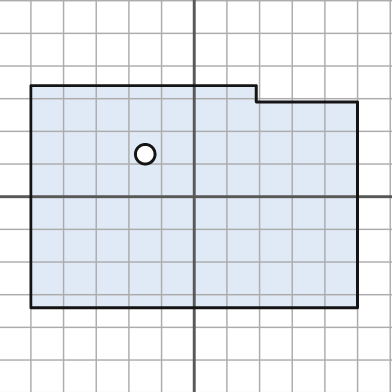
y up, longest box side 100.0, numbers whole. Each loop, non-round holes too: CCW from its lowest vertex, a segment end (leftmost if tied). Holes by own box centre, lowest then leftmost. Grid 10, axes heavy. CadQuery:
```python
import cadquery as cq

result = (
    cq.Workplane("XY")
    .moveTo(-50.0, -34.0)
    .lineTo(50.0, -34.0)
    .lineTo(50.0, 29.0)
    .lineTo(19.0, 29.0)
    .lineTo(19.0, 34.0)
    .lineTo(-50.0, 34.0)
    .close()
    .moveTo(-15.0, 13.0)
    .circle(3.0)
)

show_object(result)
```